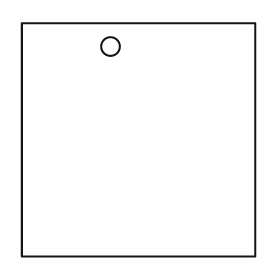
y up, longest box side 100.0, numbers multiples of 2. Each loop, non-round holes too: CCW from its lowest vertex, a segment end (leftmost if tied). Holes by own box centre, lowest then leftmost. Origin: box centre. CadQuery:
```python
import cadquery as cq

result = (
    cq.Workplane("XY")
    .moveTo(-50.0, -50.0)
    .lineTo(50.0, -50.0)
    .lineTo(50.0, 50.0)
    .lineTo(-50.0, 50.0)
    .close()
    .moveTo(-12.0, 40.0)
    .circle(4.0)
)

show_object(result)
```